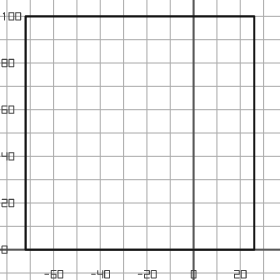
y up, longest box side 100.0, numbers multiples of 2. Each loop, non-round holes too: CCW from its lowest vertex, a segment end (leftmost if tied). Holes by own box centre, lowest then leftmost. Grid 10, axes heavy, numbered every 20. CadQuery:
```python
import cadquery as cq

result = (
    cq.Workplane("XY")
    .moveTo(-72.0, 0.0)
    .lineTo(26.0, 0.0)
    .lineTo(26.0, 100.0)
    .lineTo(-72.0, 100.0)
    .close()
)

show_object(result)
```